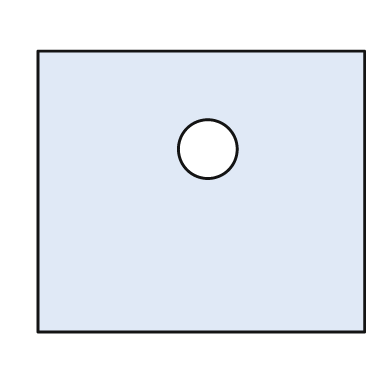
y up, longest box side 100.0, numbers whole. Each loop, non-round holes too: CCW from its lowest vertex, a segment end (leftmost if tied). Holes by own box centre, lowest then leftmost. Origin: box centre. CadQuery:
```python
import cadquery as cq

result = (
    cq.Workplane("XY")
    .moveTo(-50.0, -43.0)
    .lineTo(50.0, -43.0)
    .lineTo(50.0, 43.0)
    .lineTo(-50.0, 43.0)
    .close()
    .moveTo(2.0, 13.0)
    .circle(9.0)
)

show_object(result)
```